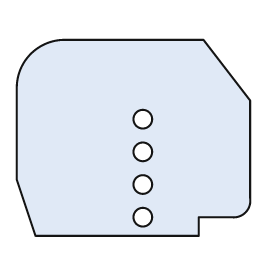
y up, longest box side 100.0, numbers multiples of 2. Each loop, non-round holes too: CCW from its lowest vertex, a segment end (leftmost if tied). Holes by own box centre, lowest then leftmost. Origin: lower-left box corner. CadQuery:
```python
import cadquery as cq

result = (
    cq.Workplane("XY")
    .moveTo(8.0, 0.0)
    .lineTo(78.0, 0.0)
    .lineTo(78.0, 8.0)
    .lineTo(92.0, 8.0)
    .threePointArc((98.0, 10.0), (100.0, 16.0))
    .lineTo(100.0, 58.0)
    .lineTo(80.0, 84.0)
    .lineTo(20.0, 84.0)
    .threePointArc((6.0, 78.0), (0.0, 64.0))
    .lineTo(0.0, 24.0)
    .close()
    .moveTo(54.0, 8.0)
    .circle(4.0)
    .moveTo(54.0, 22.0)
    .circle(4.0)
    .moveTo(54.0, 36.0)
    .circle(4.0)
    .moveTo(54.0, 50.0)
    .circle(4.0)
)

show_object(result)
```